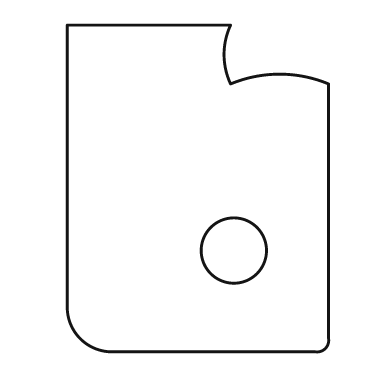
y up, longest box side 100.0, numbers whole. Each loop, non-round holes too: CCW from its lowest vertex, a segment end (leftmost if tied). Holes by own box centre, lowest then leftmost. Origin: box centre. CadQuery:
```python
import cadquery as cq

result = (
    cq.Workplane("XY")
    .moveTo(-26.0, -50.0)
    .lineTo(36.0, -50.0)
    .threePointArc((39.0, -49.0), (40.0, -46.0))
    .lineTo(40.0, 32.0)
    .threePointArc((25.0, 35.0), (10.0, 32.0))
    .threePointArc((8.0, 41.0), (10.0, 50.0))
    .lineTo(-40.0, 50.0)
    .lineTo(-40.0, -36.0)
    .threePointArc((-36.0, -46.0), (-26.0, -50.0))
    .close()
    .moveTo(11.0, -19.0)
    .circle(10.0)
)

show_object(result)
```